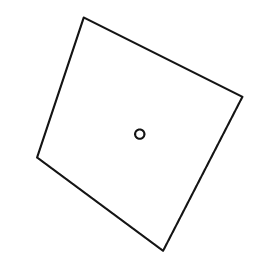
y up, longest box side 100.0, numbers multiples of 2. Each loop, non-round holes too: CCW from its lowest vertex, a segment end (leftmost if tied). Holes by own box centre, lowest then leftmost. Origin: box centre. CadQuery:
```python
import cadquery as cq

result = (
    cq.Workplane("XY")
    .moveTo(10.0, -50.0)
    .lineTo(44.0, 16.0)
    .lineTo(-24.0, 50.0)
    .lineTo(-44.0, -10.0)
    .close()
    .moveTo(0.0, 0.0)
    .circle(2.0)
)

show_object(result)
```